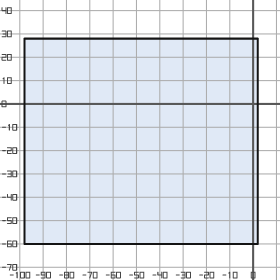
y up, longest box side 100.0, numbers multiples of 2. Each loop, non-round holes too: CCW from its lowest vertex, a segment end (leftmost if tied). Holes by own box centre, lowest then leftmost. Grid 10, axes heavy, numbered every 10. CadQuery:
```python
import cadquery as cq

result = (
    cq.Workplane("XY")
    .moveTo(-98.0, -60.0)
    .lineTo(2.0, -60.0)
    .lineTo(2.0, 28.0)
    .lineTo(-98.0, 28.0)
    .close()
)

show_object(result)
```